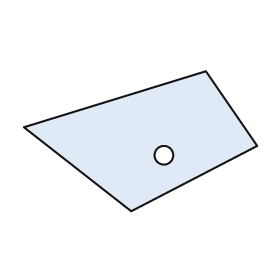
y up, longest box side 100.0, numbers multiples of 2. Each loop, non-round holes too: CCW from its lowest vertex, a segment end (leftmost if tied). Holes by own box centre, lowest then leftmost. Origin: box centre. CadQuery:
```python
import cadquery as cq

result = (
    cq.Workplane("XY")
    .moveTo(-4.0, -30.0)
    .lineTo(50.0, -2.0)
    .lineTo(28.0, 30.0)
    .lineTo(-50.0, 6.0)
    .close()
    .moveTo(10.0, -6.0)
    .circle(4.0)
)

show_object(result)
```